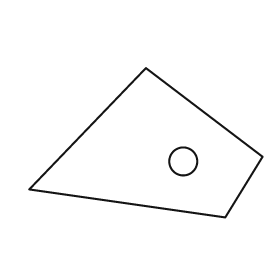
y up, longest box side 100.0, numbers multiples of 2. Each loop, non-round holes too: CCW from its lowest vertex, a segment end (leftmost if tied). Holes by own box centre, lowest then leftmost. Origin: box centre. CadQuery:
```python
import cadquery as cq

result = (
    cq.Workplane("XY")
    .moveTo(34.0, -32.0)
    .lineTo(50.0, -6.0)
    .lineTo(0.0, 32.0)
    .lineTo(-50.0, -20.0)
    .close()
    .moveTo(16.0, -8.0)
    .circle(6.0)
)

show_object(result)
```